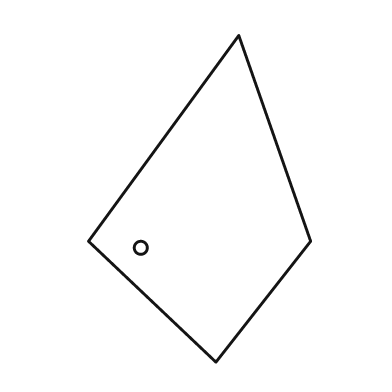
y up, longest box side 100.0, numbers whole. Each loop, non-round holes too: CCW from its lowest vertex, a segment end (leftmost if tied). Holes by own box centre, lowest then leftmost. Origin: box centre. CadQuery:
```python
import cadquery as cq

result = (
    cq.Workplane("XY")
    .moveTo(5.0, -50.0)
    .lineTo(34.0, -13.0)
    .lineTo(12.0, 50.0)
    .lineTo(-34.0, -13.0)
    .close()
    .moveTo(-18.0, -15.0)
    .circle(2.0)
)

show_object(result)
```